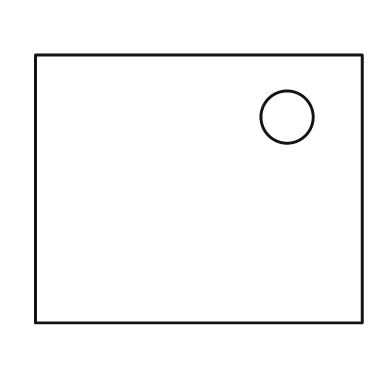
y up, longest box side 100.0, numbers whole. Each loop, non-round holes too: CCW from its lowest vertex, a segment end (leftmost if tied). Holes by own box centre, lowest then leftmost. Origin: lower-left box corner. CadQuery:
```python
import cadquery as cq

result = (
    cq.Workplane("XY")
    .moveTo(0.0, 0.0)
    .lineTo(100.0, 0.0)
    .lineTo(100.0, 82.0)
    .lineTo(0.0, 82.0)
    .close()
    .moveTo(77.0, 63.0)
    .circle(8.0)
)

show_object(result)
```